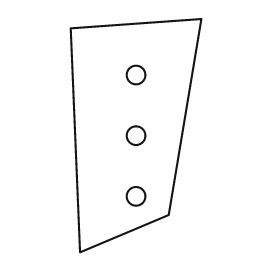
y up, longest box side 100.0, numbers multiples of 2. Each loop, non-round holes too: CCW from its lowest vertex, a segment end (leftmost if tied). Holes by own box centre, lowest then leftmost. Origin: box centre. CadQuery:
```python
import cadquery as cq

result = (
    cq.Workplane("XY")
    .moveTo(-24.0, -50.0)
    .lineTo(14.0, -34.0)
    .lineTo(28.0, 50.0)
    .lineTo(-28.0, 46.0)
    .close()
    .moveTo(0.0, -26.0)
    .circle(4.0)
    .moveTo(0.0, 0.0)
    .circle(4.0)
    .moveTo(0.0, 26.0)
    .circle(4.0)
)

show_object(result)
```